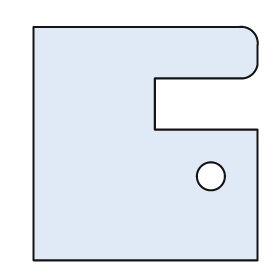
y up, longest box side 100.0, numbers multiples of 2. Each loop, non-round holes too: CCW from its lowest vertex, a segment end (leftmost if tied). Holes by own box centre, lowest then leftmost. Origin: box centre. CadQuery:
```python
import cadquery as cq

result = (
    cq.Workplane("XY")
    .moveTo(-48.0, -50.0)
    .lineTo(48.0, -50.0)
    .lineTo(48.0, 6.0)
    .lineTo(4.0, 6.0)
    .lineTo(4.0, 28.0)
    .lineTo(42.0, 28.0)
    .threePointArc((46.0, 30.0), (48.0, 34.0))
    .lineTo(48.0, 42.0)
    .threePointArc((46.0, 48.0), (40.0, 50.0))
    .lineTo(-48.0, 50.0)
    .close()
    .moveTo(28.0, -14.0)
    .circle(6.0)
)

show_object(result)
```